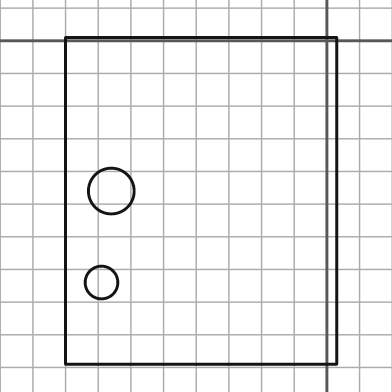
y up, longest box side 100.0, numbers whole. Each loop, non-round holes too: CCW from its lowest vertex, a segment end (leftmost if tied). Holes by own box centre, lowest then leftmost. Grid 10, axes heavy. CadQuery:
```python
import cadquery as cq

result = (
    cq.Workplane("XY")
    .moveTo(-80.0, -99.0)
    .lineTo(3.0, -99.0)
    .lineTo(3.0, 1.0)
    .lineTo(-80.0, 1.0)
    .close()
    .moveTo(-69.0, -74.0)
    .circle(5.0)
    .moveTo(-66.0, -46.0)
    .circle(7.0)
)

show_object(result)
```